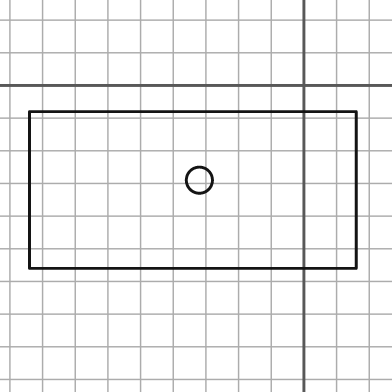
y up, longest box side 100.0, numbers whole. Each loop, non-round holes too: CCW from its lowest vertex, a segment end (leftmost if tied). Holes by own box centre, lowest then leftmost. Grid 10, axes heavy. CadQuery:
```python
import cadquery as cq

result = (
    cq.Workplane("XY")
    .moveTo(-84.0, -56.0)
    .lineTo(16.0, -56.0)
    .lineTo(16.0, -8.0)
    .lineTo(-84.0, -8.0)
    .close()
    .moveTo(-32.0, -29.0)
    .circle(4.0)
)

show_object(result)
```